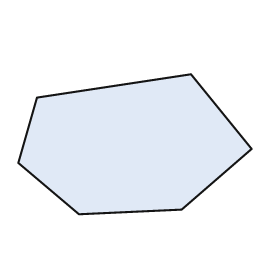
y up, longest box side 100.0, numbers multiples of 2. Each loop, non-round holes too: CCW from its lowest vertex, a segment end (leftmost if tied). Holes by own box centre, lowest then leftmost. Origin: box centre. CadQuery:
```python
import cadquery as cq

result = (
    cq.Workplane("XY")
    .moveTo(-24.0, -30.0)
    .lineTo(20.0, -28.0)
    .lineTo(50.0, -2.0)
    .lineTo(24.0, 30.0)
    .lineTo(-42.0, 20.0)
    .lineTo(-50.0, -8.0)
    .close()
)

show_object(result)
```